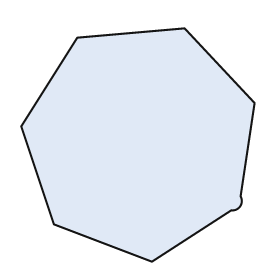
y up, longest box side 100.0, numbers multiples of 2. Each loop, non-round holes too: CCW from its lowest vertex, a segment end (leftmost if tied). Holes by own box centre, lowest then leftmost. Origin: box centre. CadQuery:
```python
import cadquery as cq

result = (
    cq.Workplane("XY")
    .moveTo(6.0, -50.0)
    .lineTo(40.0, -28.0)
    .threePointArc((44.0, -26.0), (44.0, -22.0))
    .lineTo(50.0, 18.0)
    .lineTo(20.0, 50.0)
    .lineTo(-26.0, 46.0)
    .lineTo(-50.0, 8.0)
    .lineTo(-36.0, -34.0)
    .close()
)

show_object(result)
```